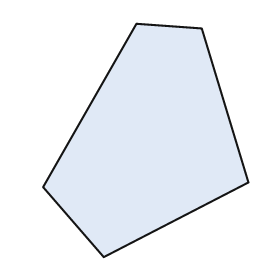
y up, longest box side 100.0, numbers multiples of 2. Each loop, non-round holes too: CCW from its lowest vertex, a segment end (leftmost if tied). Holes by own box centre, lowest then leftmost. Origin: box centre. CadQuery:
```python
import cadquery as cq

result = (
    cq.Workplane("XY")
    .moveTo(-18.0, -50.0)
    .lineTo(44.0, -18.0)
    .lineTo(24.0, 48.0)
    .lineTo(-4.0, 50.0)
    .lineTo(-44.0, -20.0)
    .close()
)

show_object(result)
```